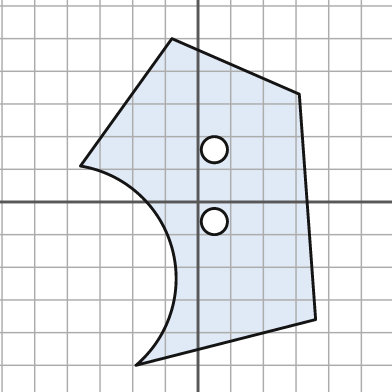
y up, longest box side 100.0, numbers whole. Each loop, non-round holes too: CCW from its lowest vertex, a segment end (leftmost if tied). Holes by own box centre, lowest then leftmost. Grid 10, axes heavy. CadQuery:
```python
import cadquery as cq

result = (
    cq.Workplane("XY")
    .moveTo(-19.0, -50.0)
    .lineTo(36.0, -36.0)
    .lineTo(31.0, 33.0)
    .lineTo(-8.0, 50.0)
    .lineTo(-36.0, 11.0)
    .threePointArc((-8.0, -14.0), (-19.0, -50.0))
    .close()
    .moveTo(5.0, -6.0)
    .circle(4.0)
    .moveTo(5.0, 16.0)
    .circle(4.0)
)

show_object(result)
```